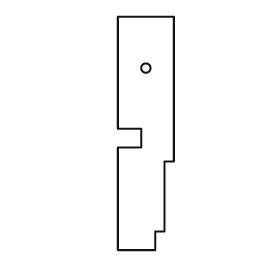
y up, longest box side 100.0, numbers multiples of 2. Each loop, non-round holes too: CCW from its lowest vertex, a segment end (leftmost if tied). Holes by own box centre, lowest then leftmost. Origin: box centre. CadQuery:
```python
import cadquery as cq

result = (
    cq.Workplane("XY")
    .moveTo(-12.0, -50.0)
    .lineTo(4.0, -50.0)
    .lineTo(4.0, -42.0)
    .lineTo(8.0, -42.0)
    .lineTo(8.0, -12.0)
    .lineTo(12.0, -12.0)
    .lineTo(12.0, 50.0)
    .lineTo(-12.0, 50.0)
    .lineTo(-12.0, 2.0)
    .lineTo(-2.0, 2.0)
    .lineTo(-2.0, -6.0)
    .lineTo(-12.0, -6.0)
    .close()
    .moveTo(0.0, 28.0)
    .circle(2.0)
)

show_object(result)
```